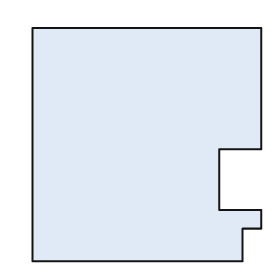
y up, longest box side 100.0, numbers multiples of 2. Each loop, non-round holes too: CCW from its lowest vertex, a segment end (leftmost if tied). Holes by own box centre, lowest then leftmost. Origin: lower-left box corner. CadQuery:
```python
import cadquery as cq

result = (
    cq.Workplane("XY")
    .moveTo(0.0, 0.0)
    .lineTo(90.0, 0.0)
    .lineTo(90.0, 14.0)
    .lineTo(98.0, 14.0)
    .lineTo(98.0, 22.0)
    .lineTo(80.0, 22.0)
    .lineTo(80.0, 48.0)
    .lineTo(98.0, 48.0)
    .lineTo(98.0, 100.0)
    .lineTo(0.0, 100.0)
    .close()
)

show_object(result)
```